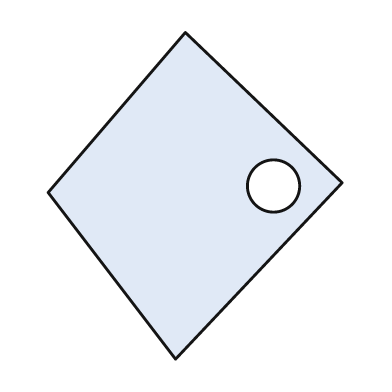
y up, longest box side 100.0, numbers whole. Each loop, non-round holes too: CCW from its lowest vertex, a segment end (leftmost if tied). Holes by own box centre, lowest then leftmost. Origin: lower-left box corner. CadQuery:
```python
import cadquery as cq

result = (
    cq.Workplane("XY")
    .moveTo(39.0, 0.0)
    .lineTo(90.0, 54.0)
    .lineTo(42.0, 100.0)
    .lineTo(0.0, 51.0)
    .close()
    .moveTo(69.0, 53.0)
    .circle(8.0)
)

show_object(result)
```